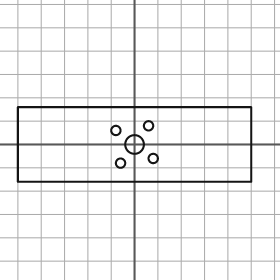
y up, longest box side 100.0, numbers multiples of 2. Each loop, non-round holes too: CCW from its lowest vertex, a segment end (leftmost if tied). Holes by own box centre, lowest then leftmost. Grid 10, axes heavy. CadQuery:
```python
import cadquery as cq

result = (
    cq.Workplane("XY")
    .moveTo(-50.0, -16.0)
    .lineTo(50.0, -16.0)
    .lineTo(50.0, 16.0)
    .lineTo(-50.0, 16.0)
    .close()
    .moveTo(-6.0, -8.0)
    .circle(2.0)
    .moveTo(8.0, -6.0)
    .circle(2.0)
    .moveTo(0.0, 0.0)
    .circle(4.0)
    .moveTo(-8.0, 6.0)
    .circle(2.0)
    .moveTo(6.0, 8.0)
    .circle(2.0)
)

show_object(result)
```